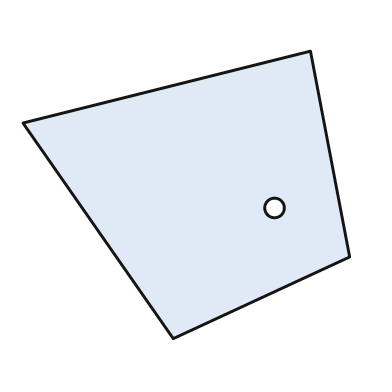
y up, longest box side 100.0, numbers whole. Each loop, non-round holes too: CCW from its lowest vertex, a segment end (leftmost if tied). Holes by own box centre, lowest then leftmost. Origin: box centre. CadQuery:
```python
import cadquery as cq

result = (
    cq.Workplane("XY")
    .moveTo(-4.0, -44.0)
    .lineTo(50.0, -19.0)
    .lineTo(38.0, 44.0)
    .lineTo(-50.0, 22.0)
    .close()
    .moveTo(27.0, -4.0)
    .circle(3.0)
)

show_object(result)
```